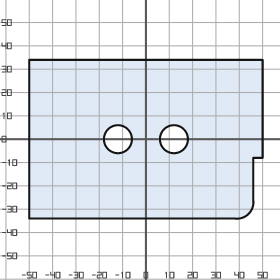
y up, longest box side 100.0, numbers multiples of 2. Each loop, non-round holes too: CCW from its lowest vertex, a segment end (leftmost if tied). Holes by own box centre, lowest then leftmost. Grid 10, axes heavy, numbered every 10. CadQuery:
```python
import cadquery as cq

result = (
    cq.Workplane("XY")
    .moveTo(-50.0, -34.0)
    .lineTo(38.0, -34.0)
    .threePointArc((44.0, -32.0), (46.0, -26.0))
    .lineTo(46.0, -8.0)
    .lineTo(50.0, -8.0)
    .lineTo(50.0, 34.0)
    .lineTo(-50.0, 34.0)
    .close()
    .moveTo(-12.0, 0.0)
    .circle(6.0)
    .moveTo(12.0, 0.0)
    .circle(6.0)
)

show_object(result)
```